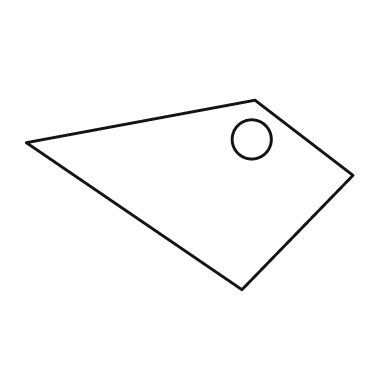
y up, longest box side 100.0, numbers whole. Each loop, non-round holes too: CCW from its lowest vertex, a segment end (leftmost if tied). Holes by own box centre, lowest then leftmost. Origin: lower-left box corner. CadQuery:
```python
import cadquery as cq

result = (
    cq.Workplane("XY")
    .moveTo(66.0, 0.0)
    .lineTo(100.0, 35.0)
    .lineTo(70.0, 58.0)
    .lineTo(0.0, 45.0)
    .close()
    .moveTo(69.0, 46.0)
    .circle(6.0)
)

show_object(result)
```